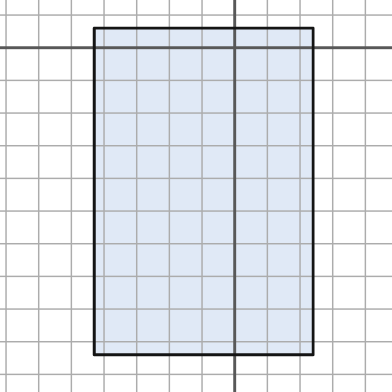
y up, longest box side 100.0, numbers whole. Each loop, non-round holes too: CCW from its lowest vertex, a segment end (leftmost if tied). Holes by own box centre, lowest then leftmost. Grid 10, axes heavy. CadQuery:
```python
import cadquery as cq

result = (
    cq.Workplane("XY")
    .moveTo(-43.0, -94.0)
    .lineTo(24.0, -94.0)
    .lineTo(24.0, 6.0)
    .lineTo(-43.0, 6.0)
    .close()
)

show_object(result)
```